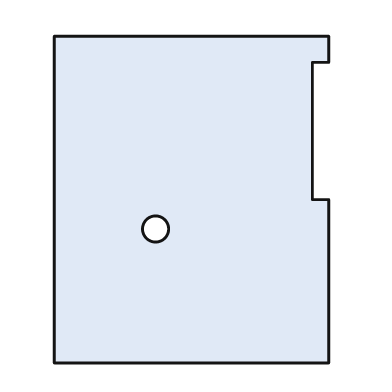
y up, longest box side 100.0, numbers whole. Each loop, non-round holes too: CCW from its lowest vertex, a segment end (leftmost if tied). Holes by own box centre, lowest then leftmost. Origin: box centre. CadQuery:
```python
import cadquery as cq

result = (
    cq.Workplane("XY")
    .moveTo(-42.0, -50.0)
    .lineTo(42.0, -50.0)
    .lineTo(42.0, 0.0)
    .lineTo(37.0, 0.0)
    .lineTo(37.0, 42.0)
    .lineTo(42.0, 42.0)
    .lineTo(42.0, 50.0)
    .lineTo(-42.0, 50.0)
    .close()
    .moveTo(-11.0, -9.0)
    .circle(4.0)
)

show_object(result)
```